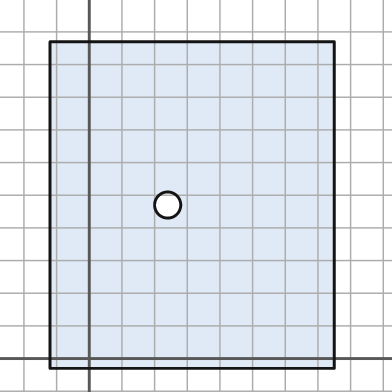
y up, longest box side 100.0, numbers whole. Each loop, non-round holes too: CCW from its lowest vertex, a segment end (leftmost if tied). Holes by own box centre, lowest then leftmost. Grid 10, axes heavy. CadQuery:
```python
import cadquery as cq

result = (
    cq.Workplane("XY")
    .moveTo(-12.0, -3.0)
    .lineTo(75.0, -3.0)
    .lineTo(75.0, 97.0)
    .lineTo(-12.0, 97.0)
    .close()
    .moveTo(24.0, 47.0)
    .circle(4.0)
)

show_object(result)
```